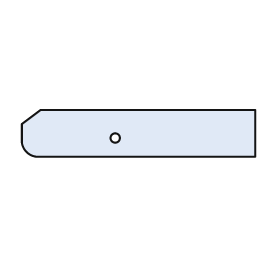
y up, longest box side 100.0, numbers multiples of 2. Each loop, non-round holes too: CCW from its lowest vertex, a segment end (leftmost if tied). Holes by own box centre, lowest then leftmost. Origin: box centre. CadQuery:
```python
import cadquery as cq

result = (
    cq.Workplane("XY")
    .moveTo(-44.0, -10.0)
    .lineTo(50.0, -10.0)
    .lineTo(50.0, 10.0)
    .lineTo(-42.0, 10.0)
    .lineTo(-50.0, 4.0)
    .lineTo(-50.0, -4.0)
    .threePointArc((-48.0, -8.0), (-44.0, -10.0))
    .close()
    .moveTo(-10.0, -2.0)
    .circle(2.0)
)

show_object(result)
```